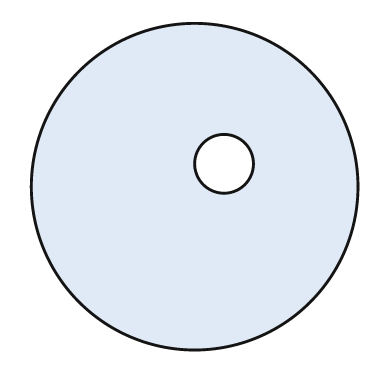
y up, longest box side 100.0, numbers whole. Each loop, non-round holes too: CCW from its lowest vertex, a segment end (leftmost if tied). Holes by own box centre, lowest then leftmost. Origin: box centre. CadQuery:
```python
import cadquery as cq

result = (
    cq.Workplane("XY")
    .moveTo(0.0, 0.0)
    .circle(50.0)
    .moveTo(9.0, 7.0)
    .circle(9.0)
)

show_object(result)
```